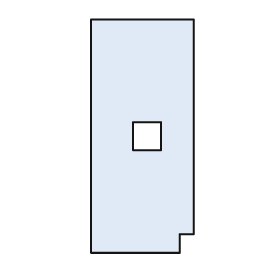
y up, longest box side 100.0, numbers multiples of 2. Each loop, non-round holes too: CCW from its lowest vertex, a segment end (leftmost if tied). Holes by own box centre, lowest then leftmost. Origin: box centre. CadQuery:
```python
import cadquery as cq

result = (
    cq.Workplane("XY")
    .moveTo(-22.0, -50.0)
    .lineTo(16.0, -50.0)
    .lineTo(16.0, -42.0)
    .lineTo(22.0, -42.0)
    .lineTo(22.0, 50.0)
    .lineTo(-22.0, 50.0)
    .close()
    .moveTo(-4.0, -6.0)
    .lineTo(8.0, -6.0)
    .lineTo(8.0, 6.0)
    .lineTo(-4.0, 6.0)
    .close()
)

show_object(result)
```